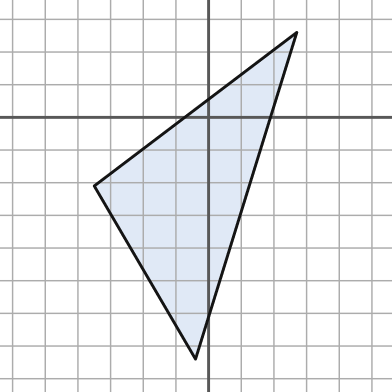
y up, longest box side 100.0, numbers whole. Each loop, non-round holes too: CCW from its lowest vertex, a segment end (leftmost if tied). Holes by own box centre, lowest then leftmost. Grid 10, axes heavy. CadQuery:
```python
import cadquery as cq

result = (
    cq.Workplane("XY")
    .moveTo(-4.0, -74.0)
    .lineTo(27.0, 26.0)
    .lineTo(-35.0, -21.0)
    .close()
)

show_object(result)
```